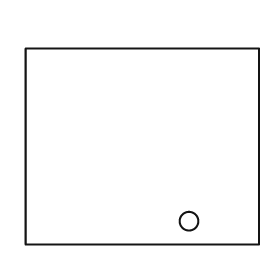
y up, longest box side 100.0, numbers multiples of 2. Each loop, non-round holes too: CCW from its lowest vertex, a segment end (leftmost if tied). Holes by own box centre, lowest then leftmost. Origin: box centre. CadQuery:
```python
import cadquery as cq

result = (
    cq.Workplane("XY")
    .moveTo(-50.0, -42.0)
    .lineTo(50.0, -42.0)
    .lineTo(50.0, 42.0)
    .lineTo(-50.0, 42.0)
    .close()
    .moveTo(20.0, -32.0)
    .circle(4.0)
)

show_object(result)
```